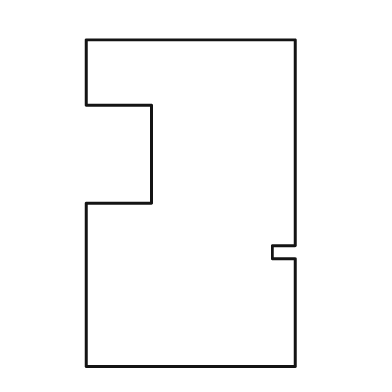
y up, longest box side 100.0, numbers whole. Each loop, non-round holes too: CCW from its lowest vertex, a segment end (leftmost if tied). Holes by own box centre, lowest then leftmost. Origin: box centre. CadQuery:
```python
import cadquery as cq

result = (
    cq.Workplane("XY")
    .moveTo(-32.0, -50.0)
    .lineTo(32.0, -50.0)
    .lineTo(32.0, -17.0)
    .lineTo(25.0, -17.0)
    .lineTo(25.0, -13.0)
    .lineTo(32.0, -13.0)
    .lineTo(32.0, 50.0)
    .lineTo(-32.0, 50.0)
    .lineTo(-32.0, 30.0)
    .lineTo(-12.0, 30.0)
    .lineTo(-12.0, 0.0)
    .lineTo(-32.0, 0.0)
    .close()
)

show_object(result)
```